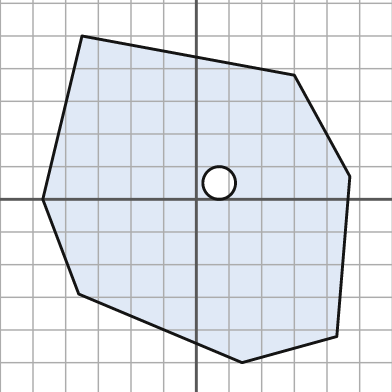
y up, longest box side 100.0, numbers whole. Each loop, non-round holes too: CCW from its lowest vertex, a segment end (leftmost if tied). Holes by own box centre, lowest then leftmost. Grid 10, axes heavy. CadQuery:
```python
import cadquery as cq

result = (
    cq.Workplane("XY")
    .moveTo(14.0, -50.0)
    .lineTo(43.0, -42.0)
    .lineTo(47.0, 7.0)
    .lineTo(30.0, 38.0)
    .lineTo(-35.0, 50.0)
    .lineTo(-47.0, 0.0)
    .lineTo(-36.0, -29.0)
    .close()
    .moveTo(7.0, 5.0)
    .circle(5.0)
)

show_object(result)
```